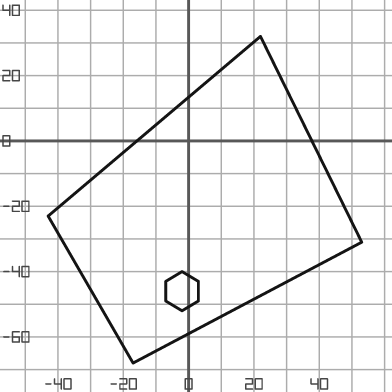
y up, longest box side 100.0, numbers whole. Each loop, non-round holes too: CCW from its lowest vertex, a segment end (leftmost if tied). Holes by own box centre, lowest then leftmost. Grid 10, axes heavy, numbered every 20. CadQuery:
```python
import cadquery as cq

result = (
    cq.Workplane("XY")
    .moveTo(-17.0, -68.0)
    .lineTo(53.0, -31.0)
    .lineTo(22.0, 32.0)
    .lineTo(-43.0, -23.0)
    .close()
    .moveTo(-2.0, -52.0)
    .lineTo(3.0, -49.0)
    .lineTo(3.0, -43.0)
    .lineTo(-2.0, -40.0)
    .lineTo(-7.0, -43.0)
    .lineTo(-7.0, -49.0)
    .close()
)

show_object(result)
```